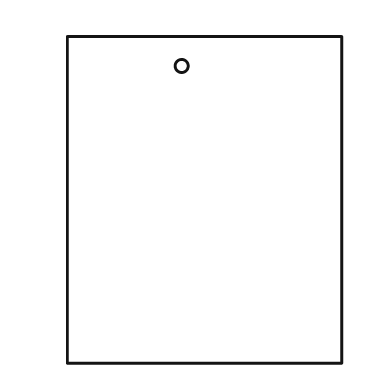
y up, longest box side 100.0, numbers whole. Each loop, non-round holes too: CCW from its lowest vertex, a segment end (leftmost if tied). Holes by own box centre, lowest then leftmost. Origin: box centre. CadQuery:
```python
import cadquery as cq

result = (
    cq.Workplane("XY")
    .moveTo(-42.0, -50.0)
    .lineTo(42.0, -50.0)
    .lineTo(42.0, 50.0)
    .lineTo(-42.0, 50.0)
    .close()
    .moveTo(-7.0, 41.0)
    .circle(2.0)
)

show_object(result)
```